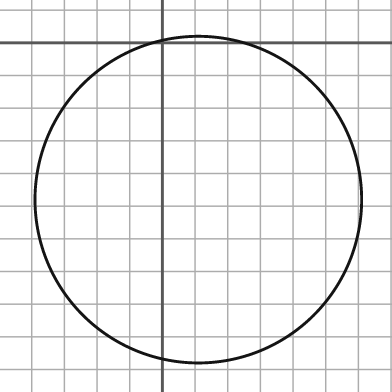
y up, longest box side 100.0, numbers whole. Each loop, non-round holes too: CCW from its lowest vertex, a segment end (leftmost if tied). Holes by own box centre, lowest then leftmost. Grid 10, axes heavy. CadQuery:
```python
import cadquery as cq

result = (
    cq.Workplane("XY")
    .moveTo(11.0, -48.0)
    .circle(50.0)
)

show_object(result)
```